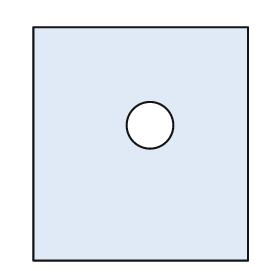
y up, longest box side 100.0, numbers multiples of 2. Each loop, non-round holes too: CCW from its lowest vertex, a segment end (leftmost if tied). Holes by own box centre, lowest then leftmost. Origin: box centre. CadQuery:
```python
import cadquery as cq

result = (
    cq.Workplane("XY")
    .moveTo(-46.0, -50.0)
    .lineTo(46.0, -50.0)
    .lineTo(46.0, 50.0)
    .lineTo(-46.0, 50.0)
    .close()
    .moveTo(4.0, 8.0)
    .circle(10.0)
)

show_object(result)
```